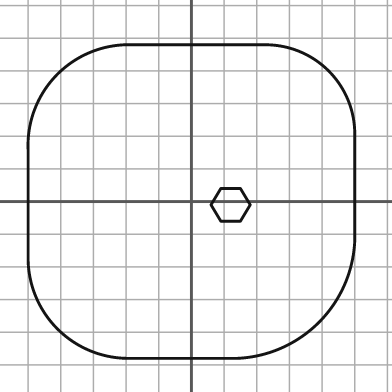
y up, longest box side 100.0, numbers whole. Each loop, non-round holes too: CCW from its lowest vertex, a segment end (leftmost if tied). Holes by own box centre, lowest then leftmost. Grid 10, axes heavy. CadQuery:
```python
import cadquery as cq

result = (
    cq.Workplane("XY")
    .moveTo(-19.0, -48.0)
    .lineTo(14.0, -48.0)
    .threePointArc((39.0, -37.0), (50.0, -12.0))
    .lineTo(50.0, 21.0)
    .threePointArc((42.0, 40.0), (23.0, 48.0))
    .lineTo(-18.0, 48.0)
    .threePointArc((-41.0, 39.0), (-50.0, 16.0))
    .lineTo(-50.0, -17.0)
    .threePointArc((-41.0, -39.0), (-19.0, -48.0))
    .close()
    .moveTo(9.0, -6.0)
    .lineTo(15.0, -6.0)
    .lineTo(18.0, -1.0)
    .lineTo(15.0, 4.0)
    .lineTo(9.0, 4.0)
    .lineTo(6.0, -1.0)
    .close()
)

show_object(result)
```